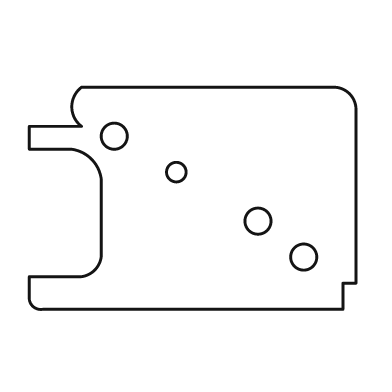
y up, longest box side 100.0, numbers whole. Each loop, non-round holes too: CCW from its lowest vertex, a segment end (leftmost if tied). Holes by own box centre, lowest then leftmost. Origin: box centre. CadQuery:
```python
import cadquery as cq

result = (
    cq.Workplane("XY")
    .moveTo(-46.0, -34.0)
    .lineTo(46.0, -34.0)
    .lineTo(46.0, -26.0)
    .lineTo(50.0, -26.0)
    .lineTo(50.0, 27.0)
    .threePointArc((48.0, 32.0), (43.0, 34.0))
    .lineTo(-34.0, 34.0)
    .threePointArc((-37.0, 28.0), (-34.0, 22.0))
    .lineTo(-50.0, 22.0)
    .lineTo(-50.0, 15.0)
    .lineTo(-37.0, 15.0)
    .threePointArc((-31.0, 12.0), (-28.0, 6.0))
    .lineTo(-28.0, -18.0)
    .threePointArc((-30.0, -22.0), (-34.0, -24.0))
    .lineTo(-50.0, -24.0)
    .lineTo(-50.0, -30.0)
    .threePointArc((-49.0, -33.0), (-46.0, -34.0))
    .close()
    .moveTo(34.0, -18.0)
    .circle(4.0)
    .moveTo(20.0, -7.0)
    .circle(4.0)
    .moveTo(-5.0, 8.0)
    .circle(3.0)
    .moveTo(-24.0, 19.0)
    .circle(4.0)
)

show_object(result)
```